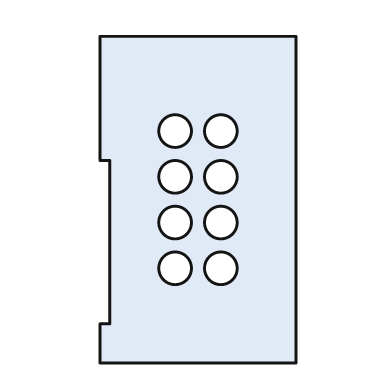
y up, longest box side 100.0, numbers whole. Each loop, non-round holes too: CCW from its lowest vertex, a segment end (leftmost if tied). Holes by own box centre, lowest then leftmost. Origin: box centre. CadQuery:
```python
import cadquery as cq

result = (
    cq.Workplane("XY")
    .moveTo(-30.0, -50.0)
    .lineTo(30.0, -50.0)
    .lineTo(30.0, 50.0)
    .lineTo(-30.0, 50.0)
    .lineTo(-30.0, 12.0)
    .lineTo(-27.0, 12.0)
    .lineTo(-27.0, -38.0)
    .lineTo(-30.0, -38.0)
    .close()
    .moveTo(-7.0, -21.0)
    .circle(5.0)
    .moveTo(7.0, -21.0)
    .circle(5.0)
    .moveTo(-7.0, -7.0)
    .circle(5.0)
    .moveTo(7.0, -7.0)
    .circle(5.0)
    .moveTo(-7.0, 7.0)
    .circle(5.0)
    .moveTo(7.0, 7.0)
    .circle(5.0)
    .moveTo(-7.0, 21.0)
    .circle(5.0)
    .moveTo(7.0, 21.0)
    .circle(5.0)
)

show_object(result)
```